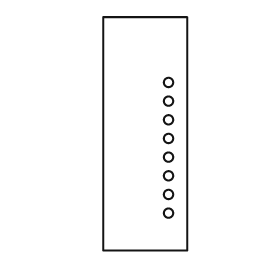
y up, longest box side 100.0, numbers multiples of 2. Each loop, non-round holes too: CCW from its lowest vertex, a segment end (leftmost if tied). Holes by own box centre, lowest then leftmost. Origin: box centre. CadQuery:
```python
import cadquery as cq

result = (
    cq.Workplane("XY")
    .moveTo(-18.0, -50.0)
    .lineTo(18.0, -50.0)
    .lineTo(18.0, 50.0)
    .lineTo(-18.0, 50.0)
    .close()
    .moveTo(10.0, -34.0)
    .circle(2.0)
    .moveTo(10.0, -26.0)
    .circle(2.0)
    .moveTo(10.0, -18.0)
    .circle(2.0)
    .moveTo(10.0, -10.0)
    .circle(2.0)
    .moveTo(10.0, -2.0)
    .circle(2.0)
    .moveTo(10.0, 6.0)
    .circle(2.0)
    .moveTo(10.0, 14.0)
    .circle(2.0)
    .moveTo(10.0, 22.0)
    .circle(2.0)
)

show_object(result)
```